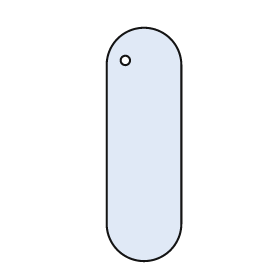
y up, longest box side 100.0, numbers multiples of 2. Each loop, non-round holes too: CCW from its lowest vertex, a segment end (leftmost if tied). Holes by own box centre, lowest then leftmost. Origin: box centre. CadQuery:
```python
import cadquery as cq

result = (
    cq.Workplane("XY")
    .moveTo(-16.0, -34.0)
    .threePointArc((0.0, -50.0), (16.0, -34.0))
    .lineTo(16.0, 34.0)
    .threePointArc((0.0, 50.0), (-16.0, 34.0))
    .close()
    .moveTo(-8.0, 36.0)
    .circle(2.0)
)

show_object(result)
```